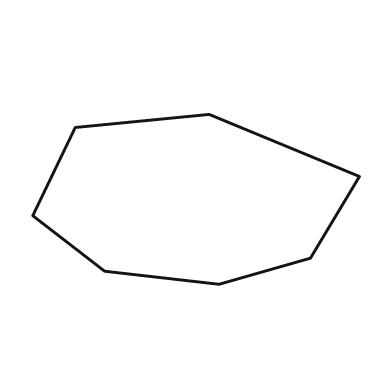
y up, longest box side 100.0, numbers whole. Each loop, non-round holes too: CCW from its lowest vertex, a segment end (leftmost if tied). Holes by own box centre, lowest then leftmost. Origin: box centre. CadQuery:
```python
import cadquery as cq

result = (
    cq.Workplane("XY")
    .moveTo(7.0, -26.0)
    .lineTo(35.0, -18.0)
    .lineTo(50.0, 7.0)
    .lineTo(4.0, 26.0)
    .lineTo(-37.0, 22.0)
    .lineTo(-50.0, -5.0)
    .lineTo(-28.0, -22.0)
    .close()
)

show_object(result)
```